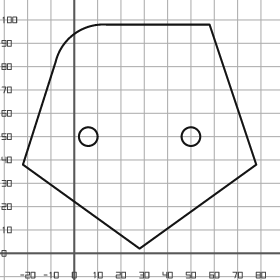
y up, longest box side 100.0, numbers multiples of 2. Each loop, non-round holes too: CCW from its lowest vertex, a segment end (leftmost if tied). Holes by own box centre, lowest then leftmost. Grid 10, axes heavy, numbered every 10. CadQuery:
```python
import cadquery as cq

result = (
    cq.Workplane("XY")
    .moveTo(28.0, 2.0)
    .lineTo(78.0, 38.0)
    .lineTo(58.0, 98.0)
    .lineTo(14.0, 98.0)
    .threePointArc((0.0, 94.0), (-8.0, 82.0))
    .lineTo(-22.0, 38.0)
    .close()
    .moveTo(6.0, 50.0)
    .circle(4.0)
    .moveTo(50.0, 50.0)
    .circle(4.0)
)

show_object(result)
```